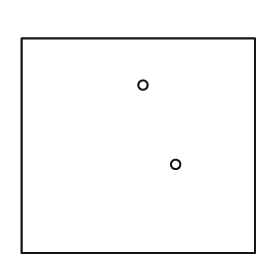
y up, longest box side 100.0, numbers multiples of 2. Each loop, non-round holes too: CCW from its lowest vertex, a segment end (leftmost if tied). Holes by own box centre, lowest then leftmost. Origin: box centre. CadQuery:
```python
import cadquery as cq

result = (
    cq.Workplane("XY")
    .moveTo(-50.0, -46.0)
    .lineTo(50.0, -46.0)
    .lineTo(50.0, 46.0)
    .lineTo(-50.0, 46.0)
    .close()
    .moveTo(16.0, -8.0)
    .circle(2.0)
    .moveTo(2.0, 26.0)
    .circle(2.0)
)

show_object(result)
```